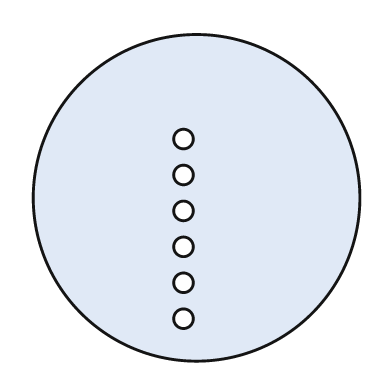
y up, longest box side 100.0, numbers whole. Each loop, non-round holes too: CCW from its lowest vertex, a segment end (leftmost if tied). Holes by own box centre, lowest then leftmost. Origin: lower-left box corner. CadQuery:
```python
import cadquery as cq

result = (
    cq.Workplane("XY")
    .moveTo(50.0, 50.0)
    .circle(50.0)
    .moveTo(46.0, 13.0)
    .circle(3.0)
    .moveTo(46.0, 24.0)
    .circle(3.0)
    .moveTo(46.0, 35.0)
    .circle(3.0)
    .moveTo(46.0, 46.0)
    .circle(3.0)
    .moveTo(46.0, 57.0)
    .circle(3.0)
    .moveTo(46.0, 68.0)
    .circle(3.0)
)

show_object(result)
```